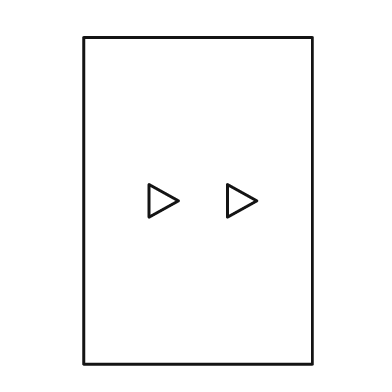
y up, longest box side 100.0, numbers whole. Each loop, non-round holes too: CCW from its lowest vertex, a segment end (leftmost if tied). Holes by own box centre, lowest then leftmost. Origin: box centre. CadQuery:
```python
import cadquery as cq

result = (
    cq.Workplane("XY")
    .moveTo(-35.0, -50.0)
    .lineTo(35.0, -50.0)
    .lineTo(35.0, 50.0)
    .lineTo(-35.0, 50.0)
    .close()
    .moveTo(-15.0, -5.0)
    .lineTo(-6.0, 0.0)
    .lineTo(-15.0, 5.0)
    .close()
    .moveTo(9.0, -5.0)
    .lineTo(18.0, 0.0)
    .lineTo(9.0, 5.0)
    .close()
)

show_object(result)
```